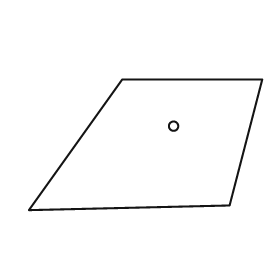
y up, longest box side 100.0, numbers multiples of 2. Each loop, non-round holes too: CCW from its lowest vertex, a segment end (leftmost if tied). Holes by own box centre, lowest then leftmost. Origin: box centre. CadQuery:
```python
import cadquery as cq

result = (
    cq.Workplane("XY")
    .moveTo(-50.0, -28.0)
    .lineTo(36.0, -26.0)
    .lineTo(50.0, 28.0)
    .lineTo(-10.0, 28.0)
    .close()
    .moveTo(12.0, 8.0)
    .circle(2.0)
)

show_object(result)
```